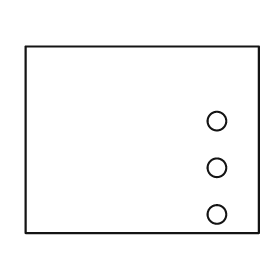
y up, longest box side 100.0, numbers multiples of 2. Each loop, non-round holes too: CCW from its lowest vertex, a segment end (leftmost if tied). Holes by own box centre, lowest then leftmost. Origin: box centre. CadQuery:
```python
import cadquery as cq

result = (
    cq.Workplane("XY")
    .moveTo(-50.0, -40.0)
    .lineTo(50.0, -40.0)
    .lineTo(50.0, 40.0)
    .lineTo(-50.0, 40.0)
    .close()
    .moveTo(32.0, -32.0)
    .circle(4.0)
    .moveTo(32.0, -12.0)
    .circle(4.0)
    .moveTo(32.0, 8.0)
    .circle(4.0)
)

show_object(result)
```